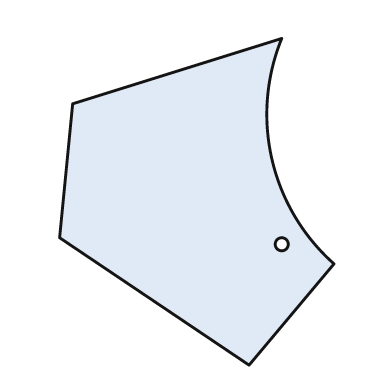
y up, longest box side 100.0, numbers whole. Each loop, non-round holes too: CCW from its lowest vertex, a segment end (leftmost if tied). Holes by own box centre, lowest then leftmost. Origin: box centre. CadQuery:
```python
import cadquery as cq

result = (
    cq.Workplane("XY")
    .moveTo(16.0, -50.0)
    .lineTo(42.0, -19.0)
    .threePointArc((23.0, 13.0), (26.0, 50.0))
    .lineTo(-38.0, 30.0)
    .lineTo(-42.0, -11.0)
    .close()
    .moveTo(26.0, -13.0)
    .circle(2.0)
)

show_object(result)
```